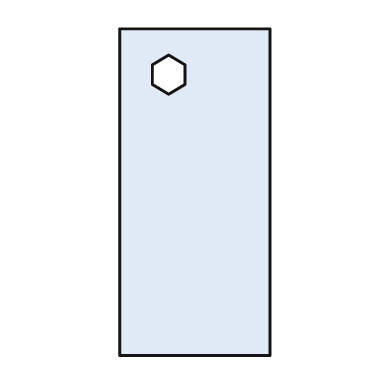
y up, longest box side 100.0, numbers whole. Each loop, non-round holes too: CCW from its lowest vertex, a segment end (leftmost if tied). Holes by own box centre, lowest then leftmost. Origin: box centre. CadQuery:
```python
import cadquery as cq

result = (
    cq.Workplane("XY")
    .moveTo(-23.0, -50.0)
    .lineTo(23.0, -50.0)
    .lineTo(23.0, 50.0)
    .lineTo(-23.0, 50.0)
    .close()
    .moveTo(-8.0, 30.0)
    .lineTo(-3.0, 33.0)
    .lineTo(-3.0, 39.0)
    .lineTo(-8.0, 42.0)
    .lineTo(-13.0, 39.0)
    .lineTo(-13.0, 33.0)
    .close()
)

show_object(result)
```